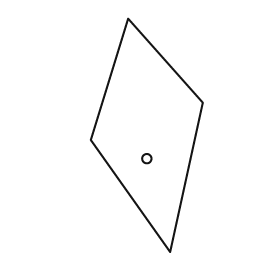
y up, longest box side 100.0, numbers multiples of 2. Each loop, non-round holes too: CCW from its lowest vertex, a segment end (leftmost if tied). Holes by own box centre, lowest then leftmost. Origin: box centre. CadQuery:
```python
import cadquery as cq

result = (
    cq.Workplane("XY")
    .moveTo(10.0, -50.0)
    .lineTo(24.0, 14.0)
    .lineTo(-8.0, 50.0)
    .lineTo(-24.0, -2.0)
    .close()
    .moveTo(0.0, -10.0)
    .circle(2.0)
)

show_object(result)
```